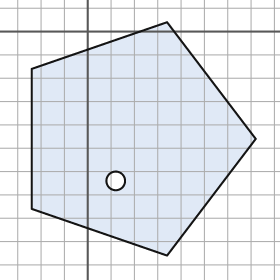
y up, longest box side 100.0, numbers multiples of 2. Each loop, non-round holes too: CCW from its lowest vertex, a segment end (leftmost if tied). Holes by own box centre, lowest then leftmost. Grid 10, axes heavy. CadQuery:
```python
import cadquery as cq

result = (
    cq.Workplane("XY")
    .moveTo(34.0, -96.0)
    .lineTo(72.0, -46.0)
    .lineTo(34.0, 4.0)
    .lineTo(-24.0, -16.0)
    .lineTo(-24.0, -76.0)
    .close()
    .moveTo(12.0, -64.0)
    .circle(4.0)
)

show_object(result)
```